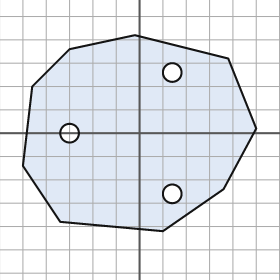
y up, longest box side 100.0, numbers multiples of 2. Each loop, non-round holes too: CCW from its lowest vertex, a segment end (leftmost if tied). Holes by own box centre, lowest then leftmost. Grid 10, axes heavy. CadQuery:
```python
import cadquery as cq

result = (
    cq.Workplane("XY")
    .moveTo(10.0, -42.0)
    .lineTo(36.0, -24.0)
    .lineTo(50.0, 2.0)
    .lineTo(38.0, 32.0)
    .lineTo(-2.0, 42.0)
    .lineTo(-30.0, 36.0)
    .lineTo(-46.0, 20.0)
    .lineTo(-50.0, -14.0)
    .lineTo(-34.0, -38.0)
    .close()
    .moveTo(14.0, -26.0)
    .circle(4.0)
    .moveTo(-30.0, 0.0)
    .circle(4.0)
    .moveTo(14.0, 26.0)
    .circle(4.0)
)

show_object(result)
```